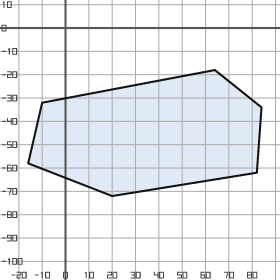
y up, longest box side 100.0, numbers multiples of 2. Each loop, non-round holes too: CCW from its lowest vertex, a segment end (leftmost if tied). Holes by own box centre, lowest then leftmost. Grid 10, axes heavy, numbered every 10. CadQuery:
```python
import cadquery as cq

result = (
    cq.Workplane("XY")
    .moveTo(20.0, -72.0)
    .lineTo(82.0, -62.0)
    .lineTo(84.0, -34.0)
    .lineTo(64.0, -18.0)
    .lineTo(-10.0, -32.0)
    .lineTo(-16.0, -58.0)
    .close()
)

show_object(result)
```